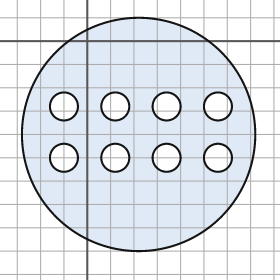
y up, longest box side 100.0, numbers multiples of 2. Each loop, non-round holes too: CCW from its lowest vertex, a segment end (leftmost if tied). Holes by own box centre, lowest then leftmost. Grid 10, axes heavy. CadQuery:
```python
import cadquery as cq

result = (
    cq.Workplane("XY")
    .moveTo(22.0, -40.0)
    .circle(50.0)
    .moveTo(-10.0, -50.0)
    .circle(6.0)
    .moveTo(12.0, -50.0)
    .circle(6.0)
    .moveTo(34.0, -50.0)
    .circle(6.0)
    .moveTo(56.0, -50.0)
    .circle(6.0)
    .moveTo(-10.0, -28.0)
    .circle(6.0)
    .moveTo(12.0, -28.0)
    .circle(6.0)
    .moveTo(34.0, -28.0)
    .circle(6.0)
    .moveTo(56.0, -28.0)
    .circle(6.0)
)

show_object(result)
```